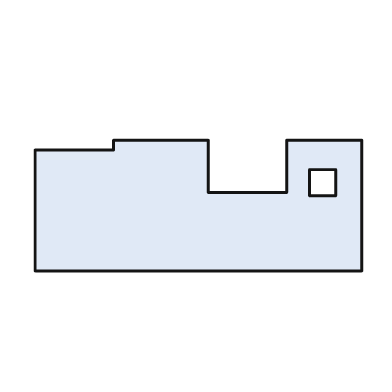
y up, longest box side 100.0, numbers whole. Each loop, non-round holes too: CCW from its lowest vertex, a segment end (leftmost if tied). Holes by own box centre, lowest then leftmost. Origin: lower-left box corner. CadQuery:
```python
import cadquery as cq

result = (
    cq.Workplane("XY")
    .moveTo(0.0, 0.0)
    .lineTo(100.0, 0.0)
    .lineTo(100.0, 40.0)
    .lineTo(77.0, 40.0)
    .lineTo(77.0, 24.0)
    .lineTo(53.0, 24.0)
    .lineTo(53.0, 40.0)
    .lineTo(24.0, 40.0)
    .lineTo(24.0, 37.0)
    .lineTo(0.0, 37.0)
    .close()
    .moveTo(84.0, 23.0)
    .lineTo(92.0, 23.0)
    .lineTo(92.0, 31.0)
    .lineTo(84.0, 31.0)
    .close()
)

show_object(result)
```